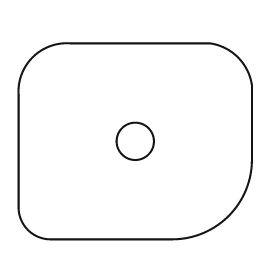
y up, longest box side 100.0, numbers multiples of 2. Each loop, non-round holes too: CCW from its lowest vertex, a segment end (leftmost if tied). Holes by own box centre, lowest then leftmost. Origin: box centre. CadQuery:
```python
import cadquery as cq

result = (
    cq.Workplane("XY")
    .moveTo(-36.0, -42.0)
    .lineTo(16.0, -42.0)
    .threePointArc((40.0, -32.0), (50.0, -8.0))
    .lineTo(50.0, 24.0)
    .threePointArc((44.0, 36.0), (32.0, 42.0))
    .lineTo(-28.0, 42.0)
    .threePointArc((-44.0, 36.0), (-50.0, 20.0))
    .lineTo(-50.0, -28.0)
    .threePointArc((-46.0, -38.0), (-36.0, -42.0))
    .close()
    .moveTo(0.0, 0.0)
    .circle(8.0)
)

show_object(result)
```